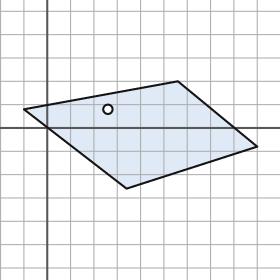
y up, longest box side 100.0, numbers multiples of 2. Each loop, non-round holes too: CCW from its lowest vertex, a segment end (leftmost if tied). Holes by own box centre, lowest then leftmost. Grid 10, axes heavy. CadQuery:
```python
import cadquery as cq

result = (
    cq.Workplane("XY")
    .moveTo(34.0, -26.0)
    .lineTo(90.0, -8.0)
    .lineTo(56.0, 20.0)
    .lineTo(-10.0, 8.0)
    .close()
    .moveTo(26.0, 8.0)
    .circle(2.0)
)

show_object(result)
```